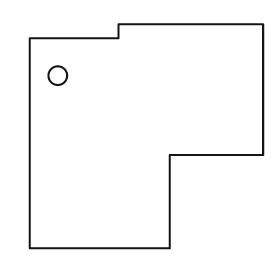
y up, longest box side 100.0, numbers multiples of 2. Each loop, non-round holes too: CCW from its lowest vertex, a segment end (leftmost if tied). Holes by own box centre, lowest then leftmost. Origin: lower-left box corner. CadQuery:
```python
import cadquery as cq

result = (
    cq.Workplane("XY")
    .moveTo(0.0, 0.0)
    .lineTo(60.0, 0.0)
    .lineTo(60.0, 40.0)
    .lineTo(100.0, 40.0)
    .lineTo(100.0, 96.0)
    .lineTo(38.0, 96.0)
    .lineTo(38.0, 90.0)
    .lineTo(0.0, 90.0)
    .close()
    .moveTo(12.0, 74.0)
    .circle(4.0)
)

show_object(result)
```